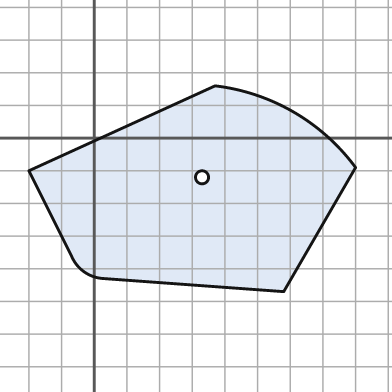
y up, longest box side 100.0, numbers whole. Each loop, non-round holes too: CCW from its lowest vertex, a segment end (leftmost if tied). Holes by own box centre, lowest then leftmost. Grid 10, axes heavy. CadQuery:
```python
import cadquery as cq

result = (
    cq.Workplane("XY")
    .moveTo(58.0, -47.0)
    .lineTo(80.0, -9.0)
    .threePointArc((61.0, 8.0), (37.0, 16.0))
    .lineTo(-20.0, -10.0)
    .lineTo(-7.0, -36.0)
    .threePointArc((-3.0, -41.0), (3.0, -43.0))
    .close()
    .moveTo(33.0, -12.0)
    .circle(2.0)
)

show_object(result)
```